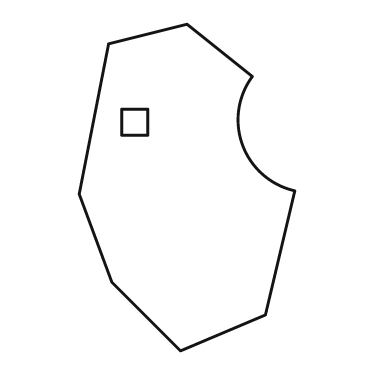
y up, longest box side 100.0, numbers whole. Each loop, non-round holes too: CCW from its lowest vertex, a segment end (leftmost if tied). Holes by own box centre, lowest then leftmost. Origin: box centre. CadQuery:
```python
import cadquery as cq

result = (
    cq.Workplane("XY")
    .moveTo(-2.0, -50.0)
    .lineTo(24.0, -39.0)
    .lineTo(33.0, -1.0)
    .threePointArc((17.0, 13.0), (20.0, 34.0))
    .lineTo(0.0, 50.0)
    .lineTo(-24.0, 44.0)
    .lineTo(-33.0, -2.0)
    .lineTo(-23.0, -29.0)
    .close()
    .moveTo(-20.0, 16.0)
    .lineTo(-12.0, 16.0)
    .lineTo(-12.0, 24.0)
    .lineTo(-20.0, 24.0)
    .close()
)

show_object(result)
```